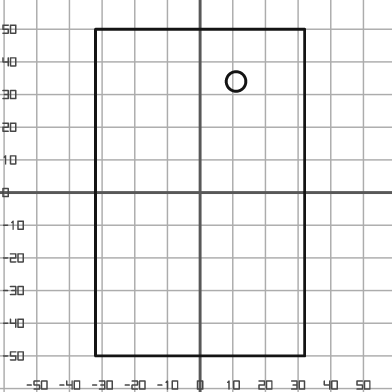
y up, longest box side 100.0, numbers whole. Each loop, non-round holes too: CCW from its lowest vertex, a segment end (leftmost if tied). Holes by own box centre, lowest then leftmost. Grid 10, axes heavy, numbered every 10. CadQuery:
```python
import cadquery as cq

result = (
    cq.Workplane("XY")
    .moveTo(-32.0, -50.0)
    .lineTo(32.0, -50.0)
    .lineTo(32.0, 50.0)
    .lineTo(-32.0, 50.0)
    .close()
    .moveTo(11.0, 34.0)
    .circle(3.0)
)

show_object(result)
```